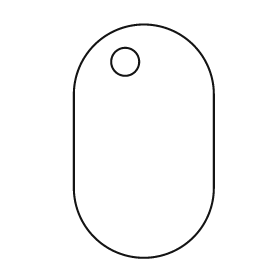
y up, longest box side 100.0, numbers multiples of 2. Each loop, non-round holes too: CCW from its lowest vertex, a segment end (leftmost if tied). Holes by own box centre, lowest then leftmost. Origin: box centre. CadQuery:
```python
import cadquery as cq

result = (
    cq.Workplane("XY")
    .moveTo(-30.0, -20.0)
    .threePointArc((0.0, -50.0), (30.0, -20.0))
    .lineTo(30.0, 20.0)
    .threePointArc((0.0, 50.0), (-30.0, 20.0))
    .close()
    .moveTo(-8.0, 34.0)
    .circle(6.0)
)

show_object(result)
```